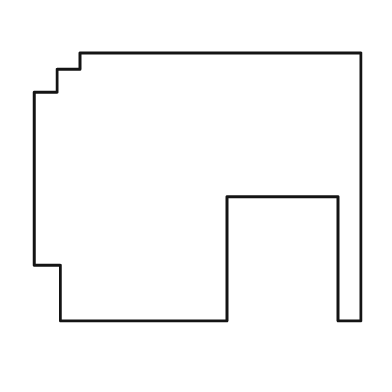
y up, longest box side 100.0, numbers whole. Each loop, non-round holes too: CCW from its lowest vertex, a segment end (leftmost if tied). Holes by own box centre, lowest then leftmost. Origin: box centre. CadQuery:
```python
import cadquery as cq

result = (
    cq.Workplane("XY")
    .moveTo(-42.0, -41.0)
    .lineTo(9.0, -41.0)
    .lineTo(9.0, -3.0)
    .lineTo(43.0, -3.0)
    .lineTo(43.0, -41.0)
    .lineTo(50.0, -41.0)
    .lineTo(50.0, 41.0)
    .lineTo(-36.0, 41.0)
    .lineTo(-36.0, 36.0)
    .lineTo(-43.0, 36.0)
    .lineTo(-43.0, 29.0)
    .lineTo(-50.0, 29.0)
    .lineTo(-50.0, -24.0)
    .lineTo(-42.0, -24.0)
    .close()
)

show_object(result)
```